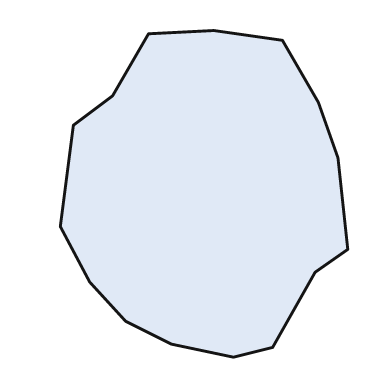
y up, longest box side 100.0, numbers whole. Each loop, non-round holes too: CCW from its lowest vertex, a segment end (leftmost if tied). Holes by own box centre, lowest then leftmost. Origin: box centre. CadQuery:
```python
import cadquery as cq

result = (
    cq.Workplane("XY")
    .moveTo(9.0, -50.0)
    .lineTo(21.0, -47.0)
    .lineTo(34.0, -24.0)
    .lineTo(44.0, -17.0)
    .lineTo(41.0, 11.0)
    .lineTo(35.0, 28.0)
    .lineTo(24.0, 47.0)
    .lineTo(3.0, 50.0)
    .lineTo(-17.0, 49.0)
    .lineTo(-28.0, 30.0)
    .lineTo(-40.0, 21.0)
    .lineTo(-44.0, -10.0)
    .lineTo(-35.0, -27.0)
    .lineTo(-24.0, -39.0)
    .lineTo(-10.0, -46.0)
    .close()
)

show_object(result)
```